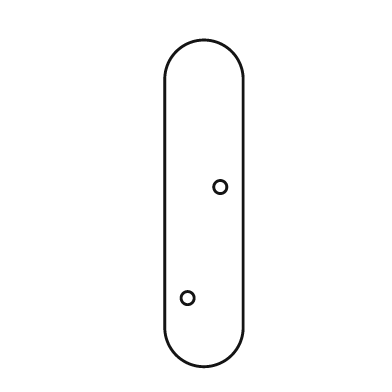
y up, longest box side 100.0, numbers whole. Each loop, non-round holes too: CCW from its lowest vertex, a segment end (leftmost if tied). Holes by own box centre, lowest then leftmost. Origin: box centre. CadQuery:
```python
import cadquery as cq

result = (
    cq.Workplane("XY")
    .moveTo(-12.0, -38.0)
    .threePointArc((0.0, -50.0), (12.0, -38.0))
    .lineTo(12.0, 38.0)
    .threePointArc((0.0, 50.0), (-12.0, 38.0))
    .close()
    .moveTo(-5.0, -29.0)
    .circle(2.0)
    .moveTo(5.0, 5.0)
    .circle(2.0)
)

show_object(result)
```